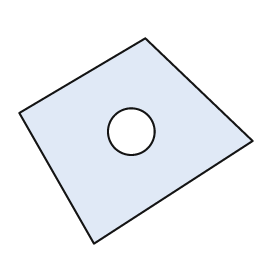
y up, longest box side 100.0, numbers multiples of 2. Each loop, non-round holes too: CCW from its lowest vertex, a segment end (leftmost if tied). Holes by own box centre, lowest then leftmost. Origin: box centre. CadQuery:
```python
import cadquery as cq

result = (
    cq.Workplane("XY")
    .moveTo(-18.0, -44.0)
    .lineTo(50.0, 0.0)
    .lineTo(4.0, 44.0)
    .lineTo(-50.0, 12.0)
    .close()
    .moveTo(-2.0, 4.0)
    .circle(10.0)
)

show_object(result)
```